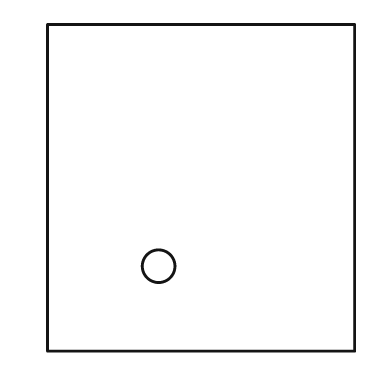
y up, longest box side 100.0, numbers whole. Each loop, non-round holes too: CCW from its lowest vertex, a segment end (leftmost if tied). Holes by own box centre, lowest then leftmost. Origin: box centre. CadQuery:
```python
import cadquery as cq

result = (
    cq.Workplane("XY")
    .moveTo(-47.0, -50.0)
    .lineTo(47.0, -50.0)
    .lineTo(47.0, 50.0)
    .lineTo(-47.0, 50.0)
    .close()
    .moveTo(-13.0, -24.0)
    .circle(5.0)
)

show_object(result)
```